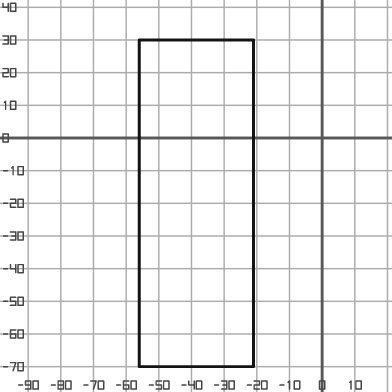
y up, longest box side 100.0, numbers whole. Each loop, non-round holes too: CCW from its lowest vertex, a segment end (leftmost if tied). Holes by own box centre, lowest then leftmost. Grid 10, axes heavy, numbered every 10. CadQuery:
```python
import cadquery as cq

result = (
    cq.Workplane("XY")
    .moveTo(-56.0, -70.0)
    .lineTo(-21.0, -70.0)
    .lineTo(-21.0, 30.0)
    .lineTo(-56.0, 30.0)
    .close()
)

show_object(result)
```